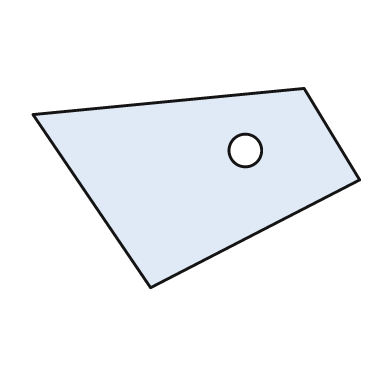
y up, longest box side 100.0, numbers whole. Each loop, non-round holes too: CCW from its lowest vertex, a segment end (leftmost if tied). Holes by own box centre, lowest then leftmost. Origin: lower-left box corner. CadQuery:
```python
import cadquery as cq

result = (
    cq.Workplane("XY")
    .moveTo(36.0, 0.0)
    .lineTo(100.0, 33.0)
    .lineTo(83.0, 61.0)
    .lineTo(0.0, 53.0)
    .close()
    .moveTo(65.0, 42.0)
    .circle(5.0)
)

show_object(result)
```